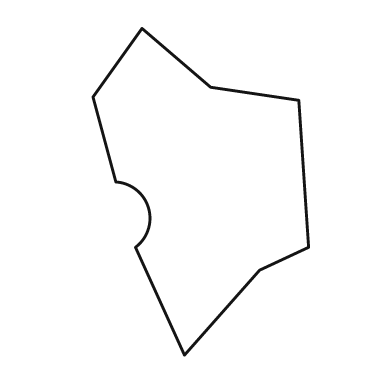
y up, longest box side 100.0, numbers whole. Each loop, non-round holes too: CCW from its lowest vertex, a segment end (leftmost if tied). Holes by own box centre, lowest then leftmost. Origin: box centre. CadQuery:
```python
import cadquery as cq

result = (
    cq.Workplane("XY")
    .moveTo(-5.0, -50.0)
    .lineTo(18.0, -24.0)
    .lineTo(33.0, -17.0)
    .lineTo(30.0, 28.0)
    .lineTo(3.0, 32.0)
    .lineTo(-18.0, 50.0)
    .lineTo(-33.0, 29.0)
    .lineTo(-26.0, 3.0)
    .threePointArc((-16.0, -5.0), (-20.0, -17.0))
    .close()
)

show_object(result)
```